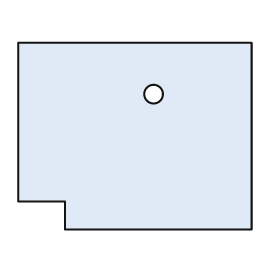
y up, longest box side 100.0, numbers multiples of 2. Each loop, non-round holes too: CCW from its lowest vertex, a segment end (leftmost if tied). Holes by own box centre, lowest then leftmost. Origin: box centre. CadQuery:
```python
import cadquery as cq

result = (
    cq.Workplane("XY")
    .moveTo(-30.0, -40.0)
    .lineTo(50.0, -40.0)
    .lineTo(50.0, 40.0)
    .lineTo(-50.0, 40.0)
    .lineTo(-50.0, -28.0)
    .lineTo(-30.0, -28.0)
    .close()
    .moveTo(8.0, 18.0)
    .circle(4.0)
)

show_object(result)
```